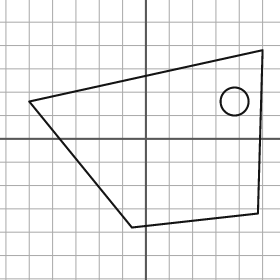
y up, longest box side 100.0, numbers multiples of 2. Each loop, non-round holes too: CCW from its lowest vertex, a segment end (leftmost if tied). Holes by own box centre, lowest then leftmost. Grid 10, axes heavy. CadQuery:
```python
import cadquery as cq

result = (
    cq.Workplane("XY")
    .moveTo(-6.0, -38.0)
    .lineTo(48.0, -32.0)
    .lineTo(50.0, 38.0)
    .lineTo(-50.0, 16.0)
    .close()
    .moveTo(38.0, 16.0)
    .circle(6.0)
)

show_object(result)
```